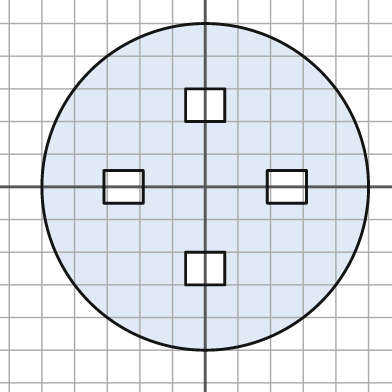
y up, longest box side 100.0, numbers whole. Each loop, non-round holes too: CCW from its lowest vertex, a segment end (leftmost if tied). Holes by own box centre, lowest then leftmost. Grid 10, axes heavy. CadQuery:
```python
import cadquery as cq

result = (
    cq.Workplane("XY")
    .moveTo(0.0, 0.0)
    .circle(50.0)
    .moveTo(-6.0, -30.0)
    .lineTo(6.0, -30.0)
    .lineTo(6.0, -20.0)
    .lineTo(-6.0, -20.0)
    .close()
    .moveTo(-31.0, -5.0)
    .lineTo(-19.0, -5.0)
    .lineTo(-19.0, 5.0)
    .lineTo(-31.0, 5.0)
    .close()
    .moveTo(19.0, -5.0)
    .lineTo(31.0, -5.0)
    .lineTo(31.0, 5.0)
    .lineTo(19.0, 5.0)
    .close()
    .moveTo(-6.0, 20.0)
    .lineTo(6.0, 20.0)
    .lineTo(6.0, 30.0)
    .lineTo(-6.0, 30.0)
    .close()
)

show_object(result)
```